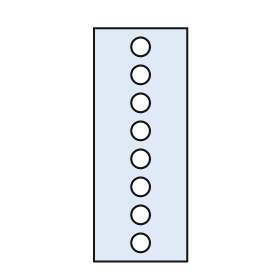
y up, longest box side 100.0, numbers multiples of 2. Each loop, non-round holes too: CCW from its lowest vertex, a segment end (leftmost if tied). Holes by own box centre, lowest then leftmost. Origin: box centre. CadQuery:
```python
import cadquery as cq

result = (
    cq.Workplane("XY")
    .moveTo(-20.0, -50.0)
    .lineTo(20.0, -50.0)
    .lineTo(20.0, 50.0)
    .lineTo(-20.0, 50.0)
    .close()
    .moveTo(0.0, -42.0)
    .circle(4.0)
    .moveTo(0.0, -30.0)
    .circle(4.0)
    .moveTo(0.0, -18.0)
    .circle(4.0)
    .moveTo(0.0, -6.0)
    .circle(4.0)
    .moveTo(0.0, 6.0)
    .circle(4.0)
    .moveTo(0.0, 18.0)
    .circle(4.0)
    .moveTo(0.0, 30.0)
    .circle(4.0)
    .moveTo(0.0, 42.0)
    .circle(4.0)
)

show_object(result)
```